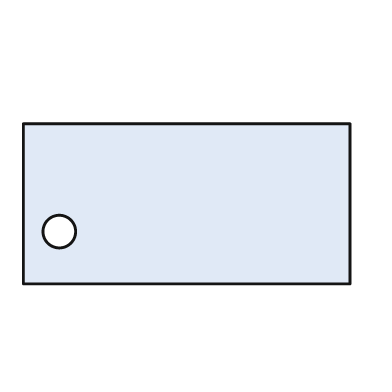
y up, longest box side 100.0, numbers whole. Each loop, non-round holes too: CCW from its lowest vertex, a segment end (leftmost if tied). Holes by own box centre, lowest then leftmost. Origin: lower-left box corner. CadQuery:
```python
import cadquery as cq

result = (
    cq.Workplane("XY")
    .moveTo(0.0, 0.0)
    .lineTo(100.0, 0.0)
    .lineTo(100.0, 49.0)
    .lineTo(0.0, 49.0)
    .close()
    .moveTo(11.0, 16.0)
    .circle(5.0)
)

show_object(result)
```